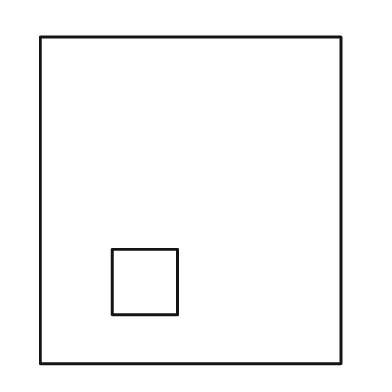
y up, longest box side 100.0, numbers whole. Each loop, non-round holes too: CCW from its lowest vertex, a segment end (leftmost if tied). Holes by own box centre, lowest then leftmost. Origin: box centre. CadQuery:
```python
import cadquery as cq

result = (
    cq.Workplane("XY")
    .moveTo(-46.0, -50.0)
    .lineTo(46.0, -50.0)
    .lineTo(46.0, 50.0)
    .lineTo(-46.0, 50.0)
    .close()
    .moveTo(-24.0, -35.0)
    .lineTo(-4.0, -35.0)
    .lineTo(-4.0, -15.0)
    .lineTo(-24.0, -15.0)
    .close()
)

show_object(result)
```